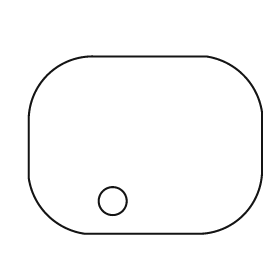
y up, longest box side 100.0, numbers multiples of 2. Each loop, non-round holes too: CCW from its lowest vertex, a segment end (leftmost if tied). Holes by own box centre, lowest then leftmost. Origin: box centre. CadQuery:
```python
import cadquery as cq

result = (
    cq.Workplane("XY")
    .moveTo(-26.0, -38.0)
    .lineTo(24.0, -38.0)
    .threePointArc((42.0, -30.0), (50.0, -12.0))
    .lineTo(50.0, 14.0)
    .threePointArc((42.0, 30.0), (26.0, 38.0))
    .lineTo(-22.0, 38.0)
    .threePointArc((-42.0, 30.0), (-50.0, 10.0))
    .lineTo(-50.0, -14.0)
    .threePointArc((-42.0, -30.0), (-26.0, -38.0))
    .close()
    .moveTo(-14.0, -24.0)
    .circle(6.0)
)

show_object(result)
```